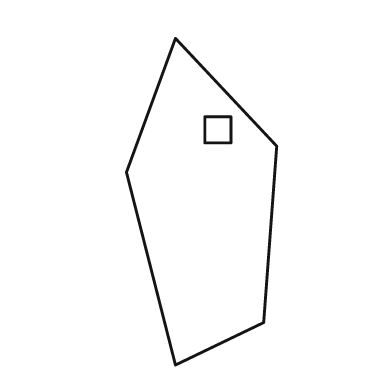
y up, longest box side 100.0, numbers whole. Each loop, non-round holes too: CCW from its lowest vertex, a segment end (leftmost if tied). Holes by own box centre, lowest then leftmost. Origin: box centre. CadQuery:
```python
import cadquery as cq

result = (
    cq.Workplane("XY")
    .moveTo(-8.0, -50.0)
    .lineTo(19.0, -37.0)
    .lineTo(23.0, 17.0)
    .lineTo(-8.0, 50.0)
    .lineTo(-23.0, 9.0)
    .close()
    .moveTo(1.0, 18.0)
    .lineTo(9.0, 18.0)
    .lineTo(9.0, 26.0)
    .lineTo(1.0, 26.0)
    .close()
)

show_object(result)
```